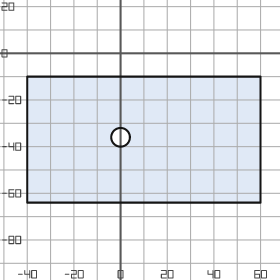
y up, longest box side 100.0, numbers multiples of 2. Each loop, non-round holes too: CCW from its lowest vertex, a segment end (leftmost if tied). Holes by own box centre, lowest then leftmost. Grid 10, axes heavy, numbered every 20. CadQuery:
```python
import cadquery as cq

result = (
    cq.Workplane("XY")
    .moveTo(-40.0, -64.0)
    .lineTo(60.0, -64.0)
    .lineTo(60.0, -10.0)
    .lineTo(-40.0, -10.0)
    .close()
    .moveTo(0.0, -36.0)
    .circle(4.0)
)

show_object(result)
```